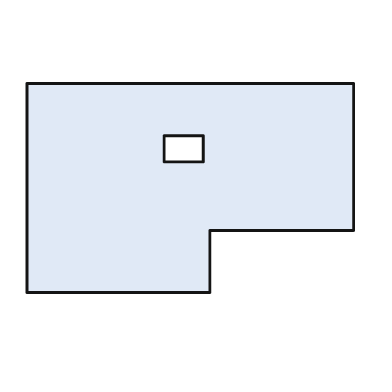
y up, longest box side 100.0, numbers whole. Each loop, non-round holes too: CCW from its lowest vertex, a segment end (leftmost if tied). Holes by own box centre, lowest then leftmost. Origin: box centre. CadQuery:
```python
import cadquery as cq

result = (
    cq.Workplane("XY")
    .moveTo(-50.0, -32.0)
    .lineTo(6.0, -32.0)
    .lineTo(6.0, -13.0)
    .lineTo(50.0, -13.0)
    .lineTo(50.0, 32.0)
    .lineTo(-50.0, 32.0)
    .close()
    .moveTo(-8.0, 8.0)
    .lineTo(4.0, 8.0)
    .lineTo(4.0, 16.0)
    .lineTo(-8.0, 16.0)
    .close()
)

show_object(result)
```